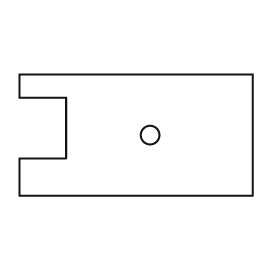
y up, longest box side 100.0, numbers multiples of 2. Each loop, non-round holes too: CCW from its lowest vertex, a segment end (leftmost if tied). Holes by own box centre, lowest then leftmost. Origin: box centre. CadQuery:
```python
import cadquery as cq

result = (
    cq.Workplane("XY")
    .moveTo(-50.0, -26.0)
    .lineTo(50.0, -26.0)
    .lineTo(50.0, 26.0)
    .lineTo(-50.0, 26.0)
    .lineTo(-50.0, 16.0)
    .lineTo(-30.0, 16.0)
    .lineTo(-30.0, -10.0)
    .lineTo(-50.0, -10.0)
    .close()
    .moveTo(6.0, 0.0)
    .circle(4.0)
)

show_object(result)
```